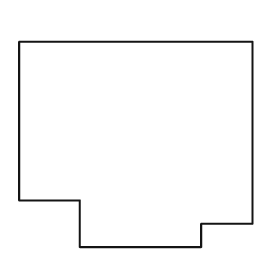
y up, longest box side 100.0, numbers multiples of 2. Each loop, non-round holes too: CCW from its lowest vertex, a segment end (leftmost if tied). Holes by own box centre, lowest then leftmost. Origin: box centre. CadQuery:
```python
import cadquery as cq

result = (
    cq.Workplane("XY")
    .moveTo(-24.0, -44.0)
    .lineTo(28.0, -44.0)
    .lineTo(28.0, -34.0)
    .lineTo(50.0, -34.0)
    .lineTo(50.0, 44.0)
    .lineTo(-50.0, 44.0)
    .lineTo(-50.0, -24.0)
    .lineTo(-24.0, -24.0)
    .close()
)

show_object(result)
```